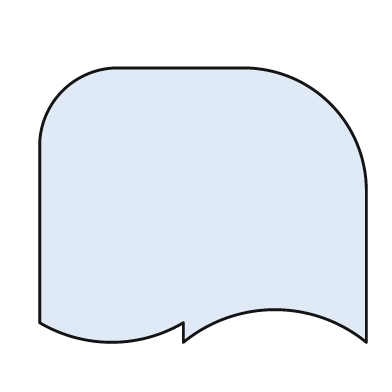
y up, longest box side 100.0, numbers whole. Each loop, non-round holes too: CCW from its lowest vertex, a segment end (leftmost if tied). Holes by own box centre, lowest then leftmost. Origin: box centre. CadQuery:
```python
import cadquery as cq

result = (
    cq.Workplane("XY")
    .moveTo(-6.0, -42.0)
    .threePointArc((22.0, -32.0), (50.0, -42.0))
    .lineTo(50.0, 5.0)
    .threePointArc((39.0, 31.0), (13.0, 42.0))
    .lineTo(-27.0, 42.0)
    .threePointArc((-43.0, 35.0), (-50.0, 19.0))
    .lineTo(-50.0, -36.0)
    .threePointArc((-28.0, -42.0), (-6.0, -36.0))
    .close()
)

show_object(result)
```